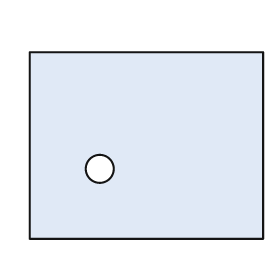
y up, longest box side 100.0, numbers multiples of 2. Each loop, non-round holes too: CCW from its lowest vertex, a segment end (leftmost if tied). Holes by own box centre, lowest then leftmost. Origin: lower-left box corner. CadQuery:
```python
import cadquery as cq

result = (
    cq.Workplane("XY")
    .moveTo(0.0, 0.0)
    .lineTo(100.0, 0.0)
    .lineTo(100.0, 80.0)
    .lineTo(0.0, 80.0)
    .close()
    .moveTo(30.0, 30.0)
    .circle(6.0)
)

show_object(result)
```